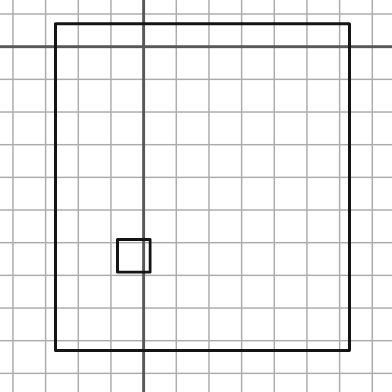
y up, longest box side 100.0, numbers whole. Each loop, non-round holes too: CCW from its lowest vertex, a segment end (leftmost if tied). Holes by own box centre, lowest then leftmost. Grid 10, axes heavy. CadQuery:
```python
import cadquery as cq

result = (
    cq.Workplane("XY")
    .moveTo(-27.0, -93.0)
    .lineTo(63.0, -93.0)
    .lineTo(63.0, 7.0)
    .lineTo(-27.0, 7.0)
    .close()
    .moveTo(-8.0, -69.0)
    .lineTo(2.0, -69.0)
    .lineTo(2.0, -59.0)
    .lineTo(-8.0, -59.0)
    .close()
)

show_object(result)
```